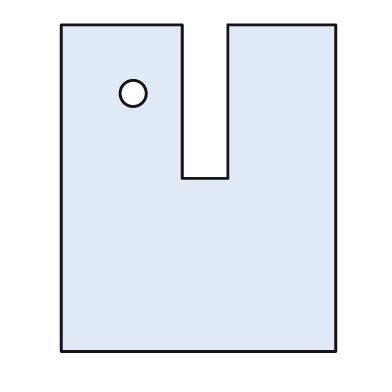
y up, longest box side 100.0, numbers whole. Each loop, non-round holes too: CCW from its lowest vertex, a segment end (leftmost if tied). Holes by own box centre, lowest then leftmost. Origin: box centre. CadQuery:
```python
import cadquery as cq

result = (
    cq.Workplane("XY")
    .moveTo(-42.0, -50.0)
    .lineTo(42.0, -50.0)
    .lineTo(42.0, 50.0)
    .lineTo(9.0, 50.0)
    .lineTo(9.0, 3.0)
    .lineTo(-5.0, 3.0)
    .lineTo(-5.0, 50.0)
    .lineTo(-42.0, 50.0)
    .close()
    .moveTo(-20.0, 29.0)
    .circle(4.0)
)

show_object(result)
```